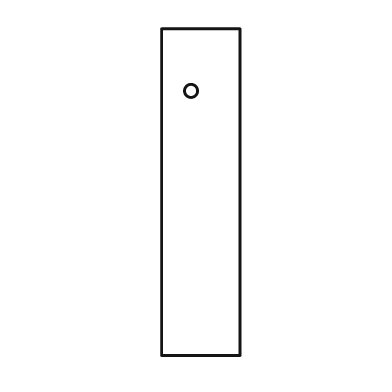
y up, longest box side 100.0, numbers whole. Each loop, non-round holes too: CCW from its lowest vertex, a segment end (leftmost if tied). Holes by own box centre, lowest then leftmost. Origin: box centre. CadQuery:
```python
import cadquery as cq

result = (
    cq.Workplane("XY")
    .moveTo(-12.0, -50.0)
    .lineTo(12.0, -50.0)
    .lineTo(12.0, 50.0)
    .lineTo(-12.0, 50.0)
    .close()
    .moveTo(-3.0, 31.0)
    .circle(2.0)
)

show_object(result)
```